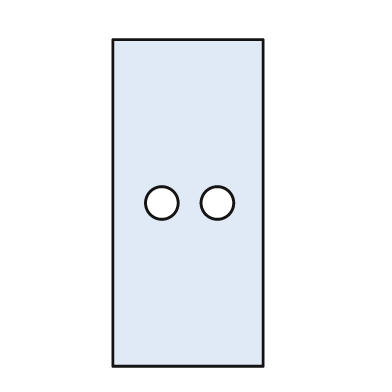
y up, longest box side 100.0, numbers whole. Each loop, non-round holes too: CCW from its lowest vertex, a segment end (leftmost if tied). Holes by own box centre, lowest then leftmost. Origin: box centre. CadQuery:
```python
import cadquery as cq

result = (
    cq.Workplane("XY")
    .moveTo(-23.0, -50.0)
    .lineTo(23.0, -50.0)
    .lineTo(23.0, 50.0)
    .lineTo(-23.0, 50.0)
    .close()
    .moveTo(-8.0, 0.0)
    .circle(5.0)
    .moveTo(9.0, 0.0)
    .circle(5.0)
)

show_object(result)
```